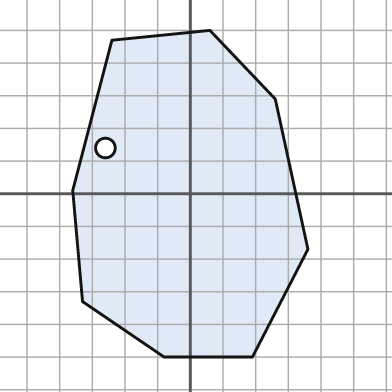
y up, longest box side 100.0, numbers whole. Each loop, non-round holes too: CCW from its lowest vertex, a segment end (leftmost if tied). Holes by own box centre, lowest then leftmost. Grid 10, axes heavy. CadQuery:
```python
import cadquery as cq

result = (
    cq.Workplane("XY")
    .moveTo(-8.0, -50.0)
    .lineTo(19.0, -50.0)
    .lineTo(36.0, -17.0)
    .lineTo(26.0, 29.0)
    .lineTo(6.0, 50.0)
    .lineTo(-24.0, 47.0)
    .lineTo(-36.0, 1.0)
    .lineTo(-33.0, -33.0)
    .close()
    .moveTo(-26.0, 14.0)
    .circle(3.0)
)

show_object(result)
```